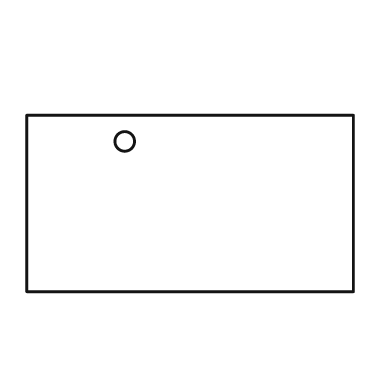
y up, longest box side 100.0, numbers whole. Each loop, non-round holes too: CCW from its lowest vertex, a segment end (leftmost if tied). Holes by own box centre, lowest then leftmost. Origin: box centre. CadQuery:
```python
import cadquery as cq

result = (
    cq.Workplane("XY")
    .moveTo(-50.0, -27.0)
    .lineTo(50.0, -27.0)
    .lineTo(50.0, 27.0)
    .lineTo(-50.0, 27.0)
    .close()
    .moveTo(-20.0, 19.0)
    .circle(3.0)
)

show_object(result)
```